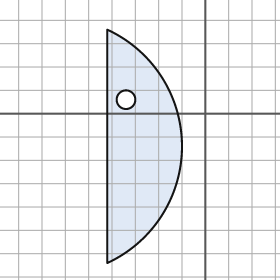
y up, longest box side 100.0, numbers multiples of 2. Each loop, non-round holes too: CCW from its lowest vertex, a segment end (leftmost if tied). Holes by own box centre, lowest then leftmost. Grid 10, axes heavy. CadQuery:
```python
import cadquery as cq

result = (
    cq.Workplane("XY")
    .moveTo(-42.0, -64.0)
    .threePointArc((-10.0, -14.0), (-42.0, 36.0))
    .close()
    .moveTo(-34.0, 6.0)
    .circle(4.0)
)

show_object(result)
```